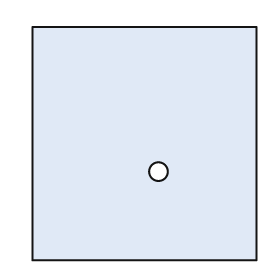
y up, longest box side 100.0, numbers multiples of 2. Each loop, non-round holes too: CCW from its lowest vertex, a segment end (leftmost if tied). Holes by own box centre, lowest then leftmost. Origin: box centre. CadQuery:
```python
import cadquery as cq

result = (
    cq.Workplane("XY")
    .moveTo(-48.0, -50.0)
    .lineTo(48.0, -50.0)
    .lineTo(48.0, 50.0)
    .lineTo(-48.0, 50.0)
    .close()
    .moveTo(6.0, -12.0)
    .circle(4.0)
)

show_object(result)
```